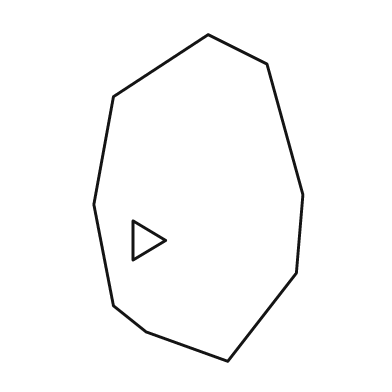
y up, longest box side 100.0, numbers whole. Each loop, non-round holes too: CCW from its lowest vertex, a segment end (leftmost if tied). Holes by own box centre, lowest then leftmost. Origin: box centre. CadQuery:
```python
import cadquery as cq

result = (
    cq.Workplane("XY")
    .moveTo(9.0, -50.0)
    .lineTo(30.0, -23.0)
    .lineTo(32.0, 1.0)
    .lineTo(21.0, 41.0)
    .lineTo(3.0, 50.0)
    .lineTo(-26.0, 31.0)
    .lineTo(-32.0, -2.0)
    .lineTo(-26.0, -33.0)
    .lineTo(-16.0, -41.0)
    .close()
    .moveTo(-20.0, -19.0)
    .lineTo(-10.0, -13.0)
    .lineTo(-20.0, -7.0)
    .close()
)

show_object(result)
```